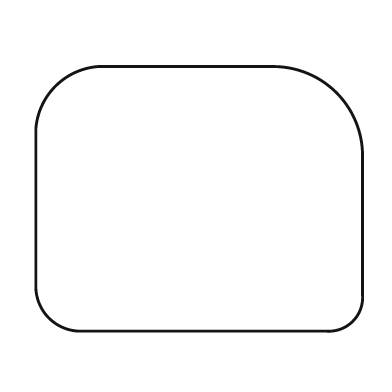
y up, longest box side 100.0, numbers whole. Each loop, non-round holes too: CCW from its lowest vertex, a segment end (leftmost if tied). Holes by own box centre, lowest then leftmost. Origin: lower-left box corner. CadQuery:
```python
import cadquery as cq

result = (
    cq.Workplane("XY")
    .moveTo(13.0, 0.0)
    .lineTo(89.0, 0.0)
    .threePointArc((97.0, 3.0), (100.0, 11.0))
    .lineTo(100.0, 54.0)
    .threePointArc((92.0, 73.0), (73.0, 81.0))
    .lineTo(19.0, 81.0)
    .threePointArc((6.0, 75.0), (0.0, 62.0))
    .lineTo(0.0, 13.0)
    .threePointArc((4.0, 4.0), (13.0, 0.0))
    .close()
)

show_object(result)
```